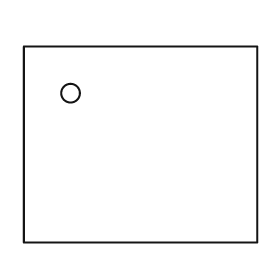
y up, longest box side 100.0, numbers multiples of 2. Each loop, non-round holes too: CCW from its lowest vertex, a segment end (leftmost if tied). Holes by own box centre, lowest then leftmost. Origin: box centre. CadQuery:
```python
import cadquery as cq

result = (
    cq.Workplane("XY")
    .moveTo(-50.0, -42.0)
    .lineTo(50.0, -42.0)
    .lineTo(50.0, 42.0)
    .lineTo(-50.0, 42.0)
    .close()
    .moveTo(-30.0, 22.0)
    .circle(4.0)
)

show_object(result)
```